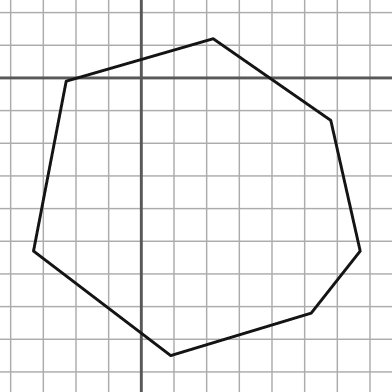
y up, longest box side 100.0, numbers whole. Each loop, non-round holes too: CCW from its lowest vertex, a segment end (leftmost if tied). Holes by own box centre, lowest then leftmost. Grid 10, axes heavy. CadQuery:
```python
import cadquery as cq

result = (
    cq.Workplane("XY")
    .moveTo(9.0, -85.0)
    .lineTo(52.0, -72.0)
    .lineTo(67.0, -53.0)
    .lineTo(58.0, -13.0)
    .lineTo(22.0, 12.0)
    .lineTo(-23.0, -1.0)
    .lineTo(-33.0, -53.0)
    .close()
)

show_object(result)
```